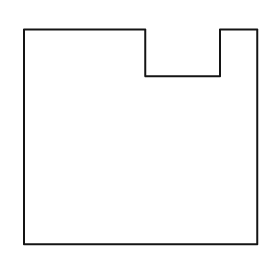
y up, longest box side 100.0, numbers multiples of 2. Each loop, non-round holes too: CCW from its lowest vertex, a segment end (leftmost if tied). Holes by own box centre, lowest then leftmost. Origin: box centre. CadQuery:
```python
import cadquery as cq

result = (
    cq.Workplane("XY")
    .moveTo(-50.0, -46.0)
    .lineTo(50.0, -46.0)
    .lineTo(50.0, 46.0)
    .lineTo(34.0, 46.0)
    .lineTo(34.0, 26.0)
    .lineTo(2.0, 26.0)
    .lineTo(2.0, 46.0)
    .lineTo(-50.0, 46.0)
    .close()
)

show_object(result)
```